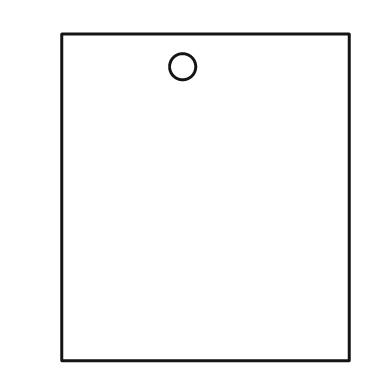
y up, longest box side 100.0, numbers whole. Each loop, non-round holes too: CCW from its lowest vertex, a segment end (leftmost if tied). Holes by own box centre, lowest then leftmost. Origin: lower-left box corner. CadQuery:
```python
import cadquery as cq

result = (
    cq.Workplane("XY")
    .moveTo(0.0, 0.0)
    .lineTo(88.0, 0.0)
    .lineTo(88.0, 100.0)
    .lineTo(0.0, 100.0)
    .close()
    .moveTo(37.0, 90.0)
    .circle(4.0)
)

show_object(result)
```